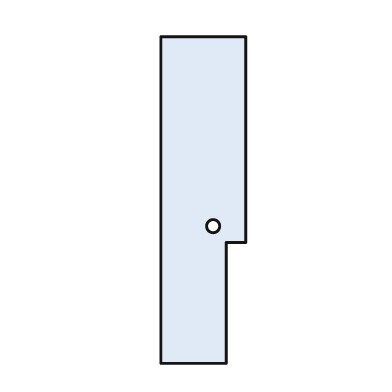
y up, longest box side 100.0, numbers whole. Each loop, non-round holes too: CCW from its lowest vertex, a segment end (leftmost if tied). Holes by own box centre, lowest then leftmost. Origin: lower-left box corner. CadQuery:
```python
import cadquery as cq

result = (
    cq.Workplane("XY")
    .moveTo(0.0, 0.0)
    .lineTo(20.0, 0.0)
    .lineTo(20.0, 37.0)
    .lineTo(26.0, 37.0)
    .lineTo(26.0, 100.0)
    .lineTo(0.0, 100.0)
    .close()
    .moveTo(16.0, 42.0)
    .circle(2.0)
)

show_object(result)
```